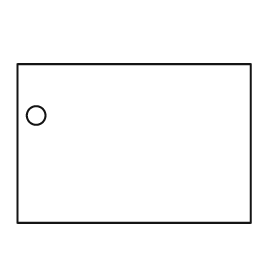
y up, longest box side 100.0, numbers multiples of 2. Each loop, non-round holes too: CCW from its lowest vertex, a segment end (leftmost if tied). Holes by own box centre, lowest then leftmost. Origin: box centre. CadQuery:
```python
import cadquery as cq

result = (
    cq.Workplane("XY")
    .moveTo(-50.0, -34.0)
    .lineTo(50.0, -34.0)
    .lineTo(50.0, 34.0)
    .lineTo(-50.0, 34.0)
    .close()
    .moveTo(-42.0, 12.0)
    .circle(4.0)
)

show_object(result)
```